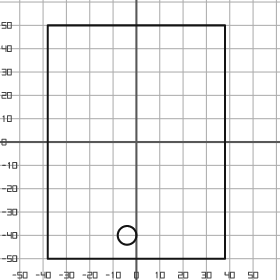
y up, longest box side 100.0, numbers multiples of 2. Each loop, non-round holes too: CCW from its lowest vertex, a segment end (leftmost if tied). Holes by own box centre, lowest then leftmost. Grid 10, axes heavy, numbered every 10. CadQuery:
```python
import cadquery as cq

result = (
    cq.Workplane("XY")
    .moveTo(-38.0, -50.0)
    .lineTo(38.0, -50.0)
    .lineTo(38.0, 50.0)
    .lineTo(-38.0, 50.0)
    .close()
    .moveTo(-4.0, -40.0)
    .circle(4.0)
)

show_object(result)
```